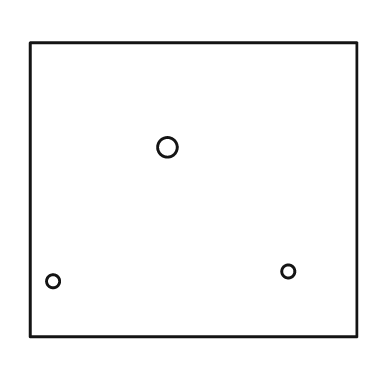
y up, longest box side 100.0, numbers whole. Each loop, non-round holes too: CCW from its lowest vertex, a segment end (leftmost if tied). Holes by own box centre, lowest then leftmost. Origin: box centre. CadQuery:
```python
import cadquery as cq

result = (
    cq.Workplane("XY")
    .moveTo(-50.0, -45.0)
    .lineTo(50.0, -45.0)
    .lineTo(50.0, 45.0)
    .lineTo(-50.0, 45.0)
    .close()
    .moveTo(-43.0, -28.0)
    .circle(2.0)
    .moveTo(29.0, -25.0)
    .circle(2.0)
    .moveTo(-8.0, 13.0)
    .circle(3.0)
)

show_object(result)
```